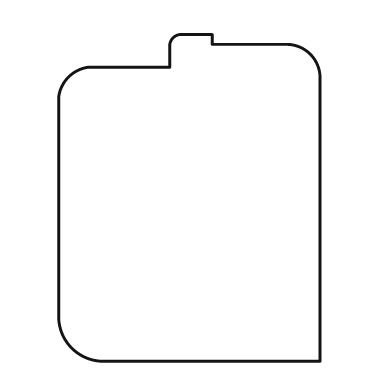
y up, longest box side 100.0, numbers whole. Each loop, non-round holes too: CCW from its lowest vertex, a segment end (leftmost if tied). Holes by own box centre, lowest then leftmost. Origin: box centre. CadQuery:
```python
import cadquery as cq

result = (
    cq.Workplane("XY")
    .moveTo(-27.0, -50.0)
    .lineTo(40.0, -50.0)
    .lineTo(40.0, 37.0)
    .threePointArc((37.0, 44.0), (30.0, 47.0))
    .lineTo(7.0, 47.0)
    .lineTo(7.0, 50.0)
    .lineTo(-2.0, 50.0)
    .threePointArc((-5.0, 49.0), (-6.0, 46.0))
    .lineTo(-6.0, 40.0)
    .lineTo(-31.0, 40.0)
    .threePointArc((-37.0, 37.0), (-40.0, 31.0))
    .lineTo(-40.0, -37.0)
    .threePointArc((-36.0, -46.0), (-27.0, -50.0))
    .close()
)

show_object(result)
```